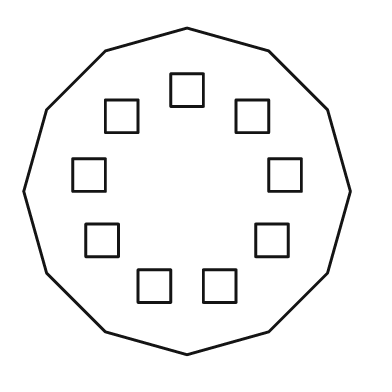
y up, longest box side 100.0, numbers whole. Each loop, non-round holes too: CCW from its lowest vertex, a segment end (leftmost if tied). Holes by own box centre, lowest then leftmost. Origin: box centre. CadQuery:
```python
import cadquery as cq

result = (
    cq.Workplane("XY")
    .moveTo(0.0, -50.0)
    .lineTo(25.0, -43.0)
    .lineTo(43.0, -25.0)
    .lineTo(50.0, 0.0)
    .lineTo(43.0, 25.0)
    .lineTo(25.0, 43.0)
    .lineTo(0.0, 50.0)
    .lineTo(-25.0, 43.0)
    .lineTo(-43.0, 25.0)
    .lineTo(-50.0, 0.0)
    .lineTo(-43.0, -25.0)
    .lineTo(-25.0, -43.0)
    .close()
    .moveTo(-15.0, -34.0)
    .lineTo(-5.0, -34.0)
    .lineTo(-5.0, -24.0)
    .lineTo(-15.0, -24.0)
    .close()
    .moveTo(5.0, -34.0)
    .lineTo(15.0, -34.0)
    .lineTo(15.0, -24.0)
    .lineTo(5.0, -24.0)
    .close()
    .moveTo(-31.0, -20.0)
    .lineTo(-21.0, -20.0)
    .lineTo(-21.0, -10.0)
    .lineTo(-31.0, -10.0)
    .close()
    .moveTo(21.0, -20.0)
    .lineTo(31.0, -20.0)
    .lineTo(31.0, -10.0)
    .lineTo(21.0, -10.0)
    .close()
    .moveTo(-35.0, 0.0)
    .lineTo(-25.0, 0.0)
    .lineTo(-25.0, 10.0)
    .lineTo(-35.0, 10.0)
    .close()
    .moveTo(25.0, 0.0)
    .lineTo(35.0, 0.0)
    .lineTo(35.0, 10.0)
    .lineTo(25.0, 10.0)
    .close()
    .moveTo(-25.0, 18.0)
    .lineTo(-15.0, 18.0)
    .lineTo(-15.0, 28.0)
    .lineTo(-25.0, 28.0)
    .close()
    .moveTo(15.0, 18.0)
    .lineTo(25.0, 18.0)
    .lineTo(25.0, 28.0)
    .lineTo(15.0, 28.0)
    .close()
    .moveTo(-5.0, 26.0)
    .lineTo(5.0, 26.0)
    .lineTo(5.0, 36.0)
    .lineTo(-5.0, 36.0)
    .close()
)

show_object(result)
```